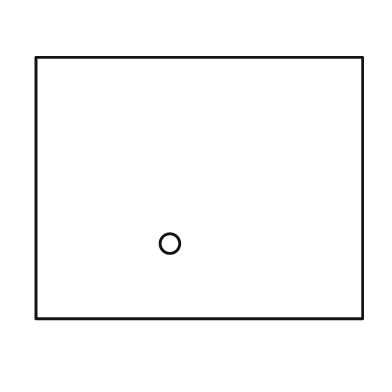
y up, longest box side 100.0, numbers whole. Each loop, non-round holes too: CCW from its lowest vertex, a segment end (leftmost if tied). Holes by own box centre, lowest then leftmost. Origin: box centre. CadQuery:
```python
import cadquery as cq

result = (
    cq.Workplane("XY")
    .moveTo(-50.0, -40.0)
    .lineTo(50.0, -40.0)
    .lineTo(50.0, 40.0)
    .lineTo(-50.0, 40.0)
    .close()
    .moveTo(-9.0, -17.0)
    .circle(3.0)
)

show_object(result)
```